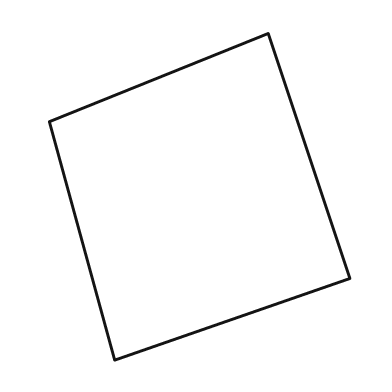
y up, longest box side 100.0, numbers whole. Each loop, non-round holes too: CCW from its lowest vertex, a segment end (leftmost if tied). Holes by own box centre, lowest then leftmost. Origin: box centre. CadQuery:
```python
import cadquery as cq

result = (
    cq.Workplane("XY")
    .moveTo(-26.0, -50.0)
    .lineTo(46.0, -25.0)
    .lineTo(21.0, 50.0)
    .lineTo(-46.0, 23.0)
    .close()
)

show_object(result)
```